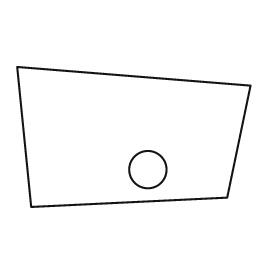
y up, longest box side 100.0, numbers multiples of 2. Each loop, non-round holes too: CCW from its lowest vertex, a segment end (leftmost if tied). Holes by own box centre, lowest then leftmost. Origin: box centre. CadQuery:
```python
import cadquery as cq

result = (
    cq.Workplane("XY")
    .moveTo(-44.0, -30.0)
    .lineTo(40.0, -26.0)
    .lineTo(50.0, 22.0)
    .lineTo(-50.0, 30.0)
    .close()
    .moveTo(6.0, -14.0)
    .circle(8.0)
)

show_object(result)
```